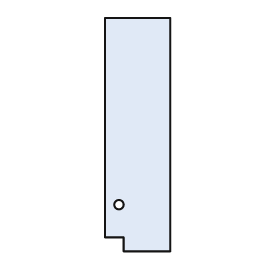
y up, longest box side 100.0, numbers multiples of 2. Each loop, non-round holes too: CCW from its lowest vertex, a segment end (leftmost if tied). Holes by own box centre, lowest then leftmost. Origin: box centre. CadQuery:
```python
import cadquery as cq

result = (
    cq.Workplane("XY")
    .moveTo(-6.0, -50.0)
    .lineTo(14.0, -50.0)
    .lineTo(14.0, 50.0)
    .lineTo(-14.0, 50.0)
    .lineTo(-14.0, -44.0)
    .lineTo(-6.0, -44.0)
    .close()
    .moveTo(-8.0, -30.0)
    .circle(2.0)
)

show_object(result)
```